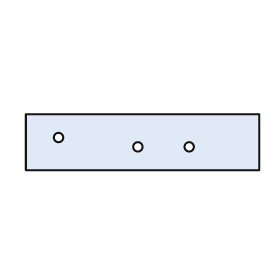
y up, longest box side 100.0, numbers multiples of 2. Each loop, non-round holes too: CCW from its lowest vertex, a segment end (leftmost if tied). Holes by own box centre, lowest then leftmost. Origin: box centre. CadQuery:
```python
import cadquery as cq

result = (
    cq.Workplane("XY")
    .moveTo(-50.0, -12.0)
    .lineTo(50.0, -12.0)
    .lineTo(50.0, 12.0)
    .lineTo(-50.0, 12.0)
    .close()
    .moveTo(-2.0, -2.0)
    .circle(2.0)
    .moveTo(20.0, -2.0)
    .circle(2.0)
    .moveTo(-36.0, 2.0)
    .circle(2.0)
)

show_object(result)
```